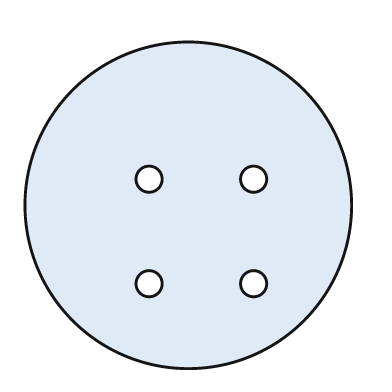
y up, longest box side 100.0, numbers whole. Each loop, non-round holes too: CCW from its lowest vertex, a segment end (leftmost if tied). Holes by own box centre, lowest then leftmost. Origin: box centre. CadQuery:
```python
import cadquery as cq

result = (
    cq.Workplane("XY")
    .moveTo(0.0, 0.0)
    .circle(50.0)
    .moveTo(-12.0, -24.0)
    .circle(4.0)
    .moveTo(20.0, -24.0)
    .circle(4.0)
    .moveTo(-12.0, 8.0)
    .circle(4.0)
    .moveTo(20.0, 8.0)
    .circle(4.0)
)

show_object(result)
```